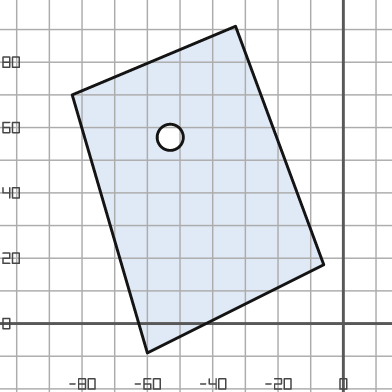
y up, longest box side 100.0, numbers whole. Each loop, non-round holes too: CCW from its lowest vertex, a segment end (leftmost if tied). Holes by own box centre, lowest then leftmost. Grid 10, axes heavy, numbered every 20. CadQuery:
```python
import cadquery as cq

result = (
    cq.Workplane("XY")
    .moveTo(-60.0, -9.0)
    .lineTo(-6.0, 18.0)
    .lineTo(-33.0, 91.0)
    .lineTo(-83.0, 70.0)
    .close()
    .moveTo(-53.0, 57.0)
    .circle(4.0)
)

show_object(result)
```